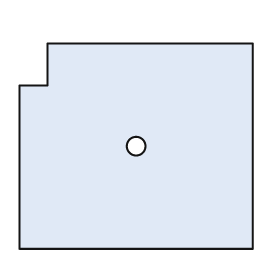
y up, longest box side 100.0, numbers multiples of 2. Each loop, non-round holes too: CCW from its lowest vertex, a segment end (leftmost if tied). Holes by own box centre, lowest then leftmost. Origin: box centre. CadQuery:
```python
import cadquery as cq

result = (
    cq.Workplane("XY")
    .moveTo(-50.0, -44.0)
    .lineTo(50.0, -44.0)
    .lineTo(50.0, 44.0)
    .lineTo(-38.0, 44.0)
    .lineTo(-38.0, 26.0)
    .lineTo(-50.0, 26.0)
    .close()
    .moveTo(0.0, 0.0)
    .circle(4.0)
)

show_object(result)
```